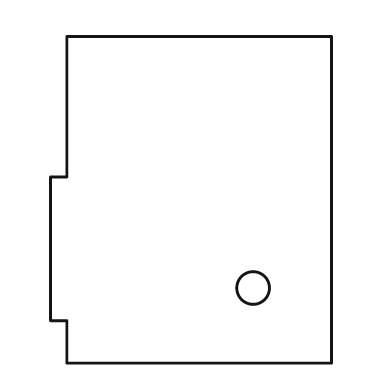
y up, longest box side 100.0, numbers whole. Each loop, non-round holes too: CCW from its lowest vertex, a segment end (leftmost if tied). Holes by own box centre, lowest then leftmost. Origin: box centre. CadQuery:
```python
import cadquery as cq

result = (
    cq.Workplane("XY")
    .moveTo(-38.0, -50.0)
    .lineTo(43.0, -50.0)
    .lineTo(43.0, 50.0)
    .lineTo(-38.0, 50.0)
    .lineTo(-38.0, 7.0)
    .lineTo(-43.0, 7.0)
    .lineTo(-43.0, -37.0)
    .lineTo(-38.0, -37.0)
    .close()
    .moveTo(19.0, -27.0)
    .circle(5.0)
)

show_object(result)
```